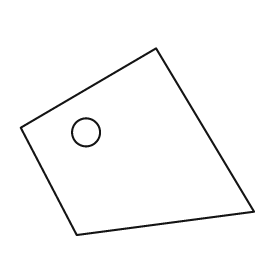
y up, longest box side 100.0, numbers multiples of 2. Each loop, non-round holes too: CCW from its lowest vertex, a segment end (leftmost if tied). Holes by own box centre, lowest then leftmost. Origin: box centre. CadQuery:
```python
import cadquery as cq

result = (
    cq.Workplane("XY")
    .moveTo(-26.0, -40.0)
    .lineTo(50.0, -30.0)
    .lineTo(8.0, 40.0)
    .lineTo(-50.0, 6.0)
    .close()
    .moveTo(-22.0, 4.0)
    .circle(6.0)
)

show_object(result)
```